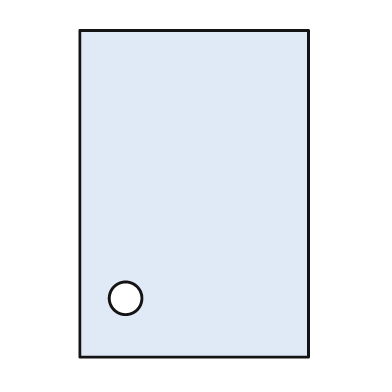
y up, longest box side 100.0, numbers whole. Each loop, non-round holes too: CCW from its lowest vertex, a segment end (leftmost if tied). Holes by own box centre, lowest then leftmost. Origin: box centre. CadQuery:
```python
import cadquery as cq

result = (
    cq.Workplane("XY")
    .moveTo(-35.0, -50.0)
    .lineTo(35.0, -50.0)
    .lineTo(35.0, 50.0)
    .lineTo(-35.0, 50.0)
    .close()
    .moveTo(-21.0, -32.0)
    .circle(5.0)
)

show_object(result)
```